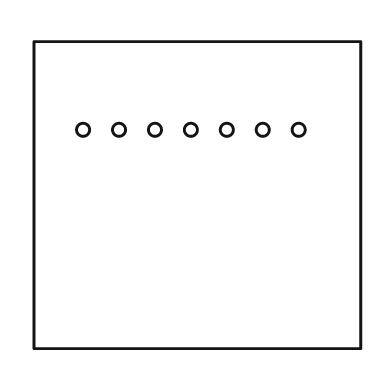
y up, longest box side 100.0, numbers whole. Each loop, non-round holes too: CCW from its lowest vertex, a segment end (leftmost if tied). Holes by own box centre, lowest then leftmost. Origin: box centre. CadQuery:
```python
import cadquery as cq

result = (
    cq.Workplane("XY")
    .moveTo(-50.0, -47.0)
    .lineTo(50.0, -47.0)
    .lineTo(50.0, 47.0)
    .lineTo(-50.0, 47.0)
    .close()
    .moveTo(-35.0, 20.0)
    .circle(2.0)
    .moveTo(-24.0, 20.0)
    .circle(2.0)
    .moveTo(-13.0, 20.0)
    .circle(2.0)
    .moveTo(-2.0, 20.0)
    .circle(2.0)
    .moveTo(9.0, 20.0)
    .circle(2.0)
    .moveTo(20.0, 20.0)
    .circle(2.0)
    .moveTo(31.0, 20.0)
    .circle(2.0)
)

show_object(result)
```